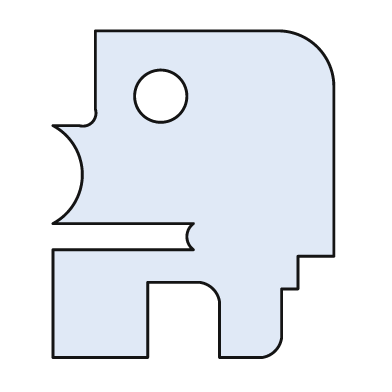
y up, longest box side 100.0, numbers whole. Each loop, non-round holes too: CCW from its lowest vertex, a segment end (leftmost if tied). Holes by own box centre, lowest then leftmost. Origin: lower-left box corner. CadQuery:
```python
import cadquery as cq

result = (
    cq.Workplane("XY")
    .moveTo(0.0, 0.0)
    .lineTo(29.0, 0.0)
    .lineTo(29.0, 23.0)
    .lineTo(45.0, 23.0)
    .threePointArc((49.0, 21.0), (51.0, 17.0))
    .lineTo(51.0, 0.0)
    .lineTo(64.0, 0.0)
    .threePointArc((68.0, 2.0), (70.0, 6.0))
    .lineTo(70.0, 21.0)
    .lineTo(75.0, 21.0)
    .lineTo(75.0, 31.0)
    .lineTo(86.0, 31.0)
    .lineTo(86.0, 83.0)
    .threePointArc((81.0, 95.0), (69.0, 100.0))
    .lineTo(13.0, 100.0)
    .lineTo(13.0, 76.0)
    .threePointArc((12.0, 72.0), (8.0, 71.0))
    .lineTo(0.0, 71.0)
    .threePointArc((9.0, 56.0), (0.0, 41.0))
    .lineTo(43.0, 41.0)
    .threePointArc((41.0, 37.0), (43.0, 33.0))
    .lineTo(0.0, 33.0)
    .close()
    .moveTo(33.0, 80.0)
    .circle(8.0)
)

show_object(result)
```